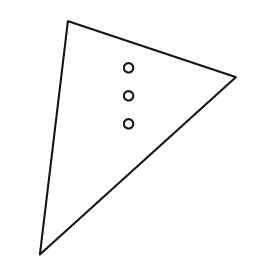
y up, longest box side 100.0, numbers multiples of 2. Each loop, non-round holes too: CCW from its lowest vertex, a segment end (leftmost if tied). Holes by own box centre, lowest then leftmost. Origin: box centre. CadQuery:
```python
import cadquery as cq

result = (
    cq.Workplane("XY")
    .moveTo(-42.0, -50.0)
    .lineTo(42.0, 26.0)
    .lineTo(-30.0, 50.0)
    .close()
    .moveTo(-4.0, 6.0)
    .circle(2.0)
    .moveTo(-4.0, 18.0)
    .circle(2.0)
    .moveTo(-4.0, 30.0)
    .circle(2.0)
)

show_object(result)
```